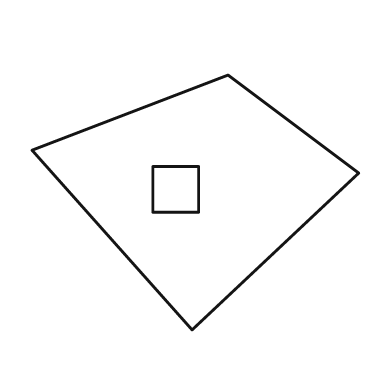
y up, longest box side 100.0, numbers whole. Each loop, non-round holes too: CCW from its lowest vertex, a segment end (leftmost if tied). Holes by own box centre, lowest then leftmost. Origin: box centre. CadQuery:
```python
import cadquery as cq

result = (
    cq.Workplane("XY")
    .moveTo(-1.0, -39.0)
    .lineTo(50.0, 9.0)
    .lineTo(10.0, 39.0)
    .lineTo(-50.0, 16.0)
    .close()
    .moveTo(-13.0, -3.0)
    .lineTo(1.0, -3.0)
    .lineTo(1.0, 11.0)
    .lineTo(-13.0, 11.0)
    .close()
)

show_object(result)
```